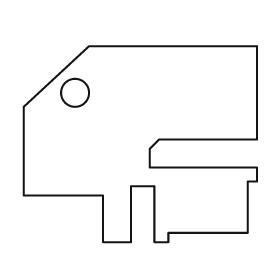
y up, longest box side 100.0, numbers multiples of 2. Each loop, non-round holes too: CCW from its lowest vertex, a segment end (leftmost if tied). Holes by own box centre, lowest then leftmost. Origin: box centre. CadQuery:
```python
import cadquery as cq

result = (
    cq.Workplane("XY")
    .moveTo(-16.0, -42.0)
    .lineTo(-4.0, -42.0)
    .lineTo(-4.0, -18.0)
    .lineTo(6.0, -18.0)
    .lineTo(6.0, -42.0)
    .lineTo(12.0, -42.0)
    .lineTo(12.0, -38.0)
    .lineTo(46.0, -38.0)
    .lineTo(46.0, -16.0)
    .lineTo(50.0, -16.0)
    .lineTo(50.0, -10.0)
    .lineTo(4.0, -10.0)
    .lineTo(4.0, -2.0)
    .lineTo(8.0, 2.0)
    .lineTo(50.0, 2.0)
    .lineTo(50.0, 42.0)
    .lineTo(-22.0, 42.0)
    .lineTo(-50.0, 16.0)
    .lineTo(-50.0, -22.0)
    .lineTo(-16.0, -22.0)
    .close()
    .moveTo(-28.0, 22.0)
    .circle(6.0)
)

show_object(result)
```